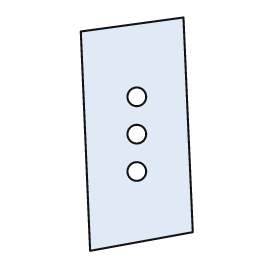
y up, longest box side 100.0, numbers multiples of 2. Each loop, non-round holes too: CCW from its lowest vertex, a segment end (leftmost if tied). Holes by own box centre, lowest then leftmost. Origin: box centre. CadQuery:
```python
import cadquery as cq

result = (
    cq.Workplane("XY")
    .moveTo(-20.0, -50.0)
    .lineTo(24.0, -42.0)
    .lineTo(20.0, 50.0)
    .lineTo(-24.0, 44.0)
    .close()
    .moveTo(0.0, -16.0)
    .circle(4.0)
    .moveTo(0.0, 0.0)
    .circle(4.0)
    .moveTo(0.0, 16.0)
    .circle(4.0)
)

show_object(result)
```